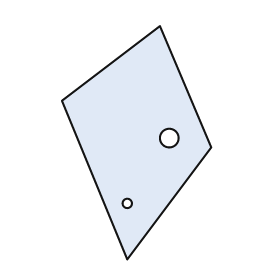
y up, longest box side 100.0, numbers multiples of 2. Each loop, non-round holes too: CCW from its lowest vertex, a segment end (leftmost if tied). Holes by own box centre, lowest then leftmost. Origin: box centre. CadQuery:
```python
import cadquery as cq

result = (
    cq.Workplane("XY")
    .moveTo(-4.0, -50.0)
    .lineTo(32.0, -2.0)
    .lineTo(10.0, 50.0)
    .lineTo(-32.0, 18.0)
    .close()
    .moveTo(-4.0, -26.0)
    .circle(2.0)
    .moveTo(14.0, 2.0)
    .circle(4.0)
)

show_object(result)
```